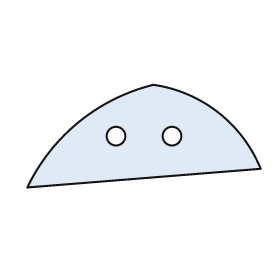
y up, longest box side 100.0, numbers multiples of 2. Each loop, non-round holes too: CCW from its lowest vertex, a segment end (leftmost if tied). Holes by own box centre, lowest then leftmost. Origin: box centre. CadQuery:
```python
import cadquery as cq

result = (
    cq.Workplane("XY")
    .moveTo(-50.0, -22.0)
    .lineTo(50.0, -14.0)
    .threePointArc((32.0, 10.0), (4.0, 22.0))
    .threePointArc((-28.0, 6.0), (-50.0, -22.0))
    .close()
    .moveTo(-12.0, 0.0)
    .circle(4.0)
    .moveTo(12.0, 0.0)
    .circle(4.0)
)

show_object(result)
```